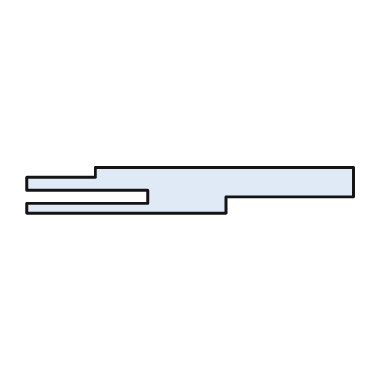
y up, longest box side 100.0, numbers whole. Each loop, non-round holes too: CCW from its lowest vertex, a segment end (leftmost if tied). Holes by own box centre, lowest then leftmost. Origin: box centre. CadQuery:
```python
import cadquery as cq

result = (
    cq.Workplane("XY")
    .moveTo(-50.0, -7.0)
    .lineTo(11.0, -7.0)
    .lineTo(11.0, -2.0)
    .lineTo(50.0, -2.0)
    .lineTo(50.0, 7.0)
    .lineTo(-29.0, 7.0)
    .lineTo(-29.0, 4.0)
    .lineTo(-50.0, 4.0)
    .lineTo(-50.0, 0.0)
    .lineTo(-13.0, 0.0)
    .lineTo(-13.0, -4.0)
    .lineTo(-50.0, -4.0)
    .close()
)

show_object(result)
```